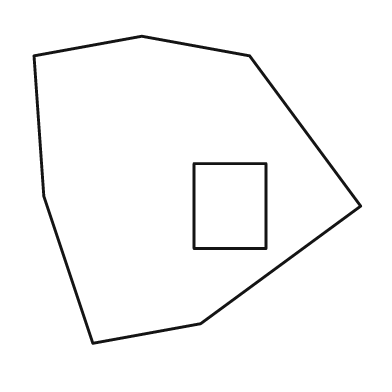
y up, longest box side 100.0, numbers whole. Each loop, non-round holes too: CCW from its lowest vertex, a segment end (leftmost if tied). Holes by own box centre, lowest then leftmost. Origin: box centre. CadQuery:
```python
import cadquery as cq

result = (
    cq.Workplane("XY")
    .moveTo(-32.0, -47.0)
    .lineTo(1.0, -41.0)
    .lineTo(50.0, -5.0)
    .lineTo(16.0, 41.0)
    .lineTo(-17.0, 47.0)
    .lineTo(-50.0, 41.0)
    .lineTo(-47.0, -2.0)
    .close()
    .moveTo(-1.0, -18.0)
    .lineTo(21.0, -18.0)
    .lineTo(21.0, 8.0)
    .lineTo(-1.0, 8.0)
    .close()
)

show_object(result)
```